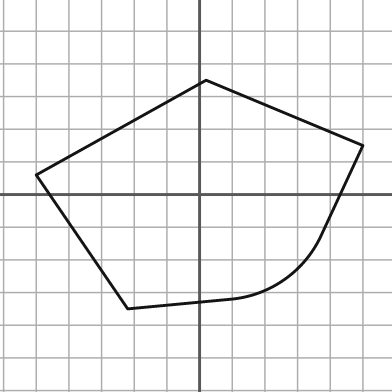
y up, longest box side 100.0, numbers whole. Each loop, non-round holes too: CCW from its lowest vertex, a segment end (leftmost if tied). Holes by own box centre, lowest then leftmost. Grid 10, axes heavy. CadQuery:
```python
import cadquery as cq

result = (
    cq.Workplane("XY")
    .moveTo(-22.0, -35.0)
    .lineTo(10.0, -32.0)
    .threePointArc((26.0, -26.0), (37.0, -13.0))
    .lineTo(50.0, 15.0)
    .lineTo(2.0, 35.0)
    .lineTo(-50.0, 6.0)
    .close()
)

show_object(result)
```